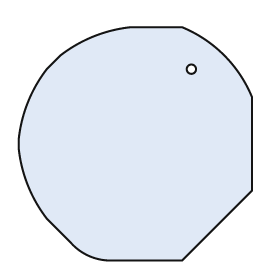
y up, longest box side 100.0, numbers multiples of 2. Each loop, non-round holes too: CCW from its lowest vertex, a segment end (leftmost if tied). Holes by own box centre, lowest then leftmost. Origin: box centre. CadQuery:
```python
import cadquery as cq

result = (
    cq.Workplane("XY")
    .moveTo(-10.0, -50.0)
    .lineTo(20.0, -50.0)
    .lineTo(50.0, -20.0)
    .lineTo(50.0, 20.0)
    .threePointArc((38.0, 38.0), (20.0, 50.0))
    .lineTo(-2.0, 50.0)
    .threePointArc((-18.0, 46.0), (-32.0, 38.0))
    .lineTo(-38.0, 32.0)
    .threePointArc((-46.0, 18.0), (-50.0, 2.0))
    .lineTo(-50.0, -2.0)
    .threePointArc((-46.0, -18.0), (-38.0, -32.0))
    .lineTo(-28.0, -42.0)
    .threePointArc((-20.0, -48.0), (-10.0, -50.0))
    .close()
    .moveTo(24.0, 32.0)
    .circle(2.0)
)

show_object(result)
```